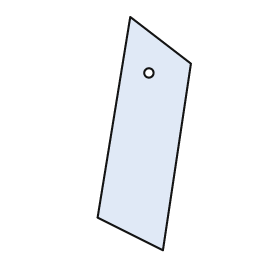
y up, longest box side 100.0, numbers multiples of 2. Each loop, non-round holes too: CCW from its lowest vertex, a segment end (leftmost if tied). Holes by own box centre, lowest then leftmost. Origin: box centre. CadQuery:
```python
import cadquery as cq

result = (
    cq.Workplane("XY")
    .moveTo(8.0, -50.0)
    .lineTo(20.0, 30.0)
    .lineTo(-6.0, 50.0)
    .lineTo(-20.0, -36.0)
    .close()
    .moveTo(2.0, 26.0)
    .circle(2.0)
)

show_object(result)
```